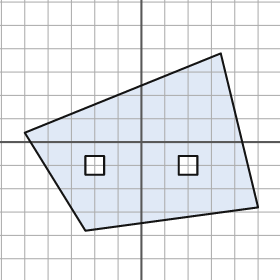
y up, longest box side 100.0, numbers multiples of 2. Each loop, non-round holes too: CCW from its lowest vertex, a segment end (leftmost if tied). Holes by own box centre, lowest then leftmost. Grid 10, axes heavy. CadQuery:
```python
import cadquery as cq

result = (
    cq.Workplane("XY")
    .moveTo(-24.0, -38.0)
    .lineTo(50.0, -28.0)
    .lineTo(34.0, 38.0)
    .lineTo(-50.0, 4.0)
    .close()
    .moveTo(-24.0, -14.0)
    .lineTo(-16.0, -14.0)
    .lineTo(-16.0, -6.0)
    .lineTo(-24.0, -6.0)
    .close()
    .moveTo(16.0, -14.0)
    .lineTo(24.0, -14.0)
    .lineTo(24.0, -6.0)
    .lineTo(16.0, -6.0)
    .close()
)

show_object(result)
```